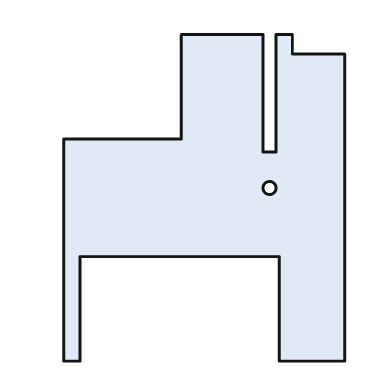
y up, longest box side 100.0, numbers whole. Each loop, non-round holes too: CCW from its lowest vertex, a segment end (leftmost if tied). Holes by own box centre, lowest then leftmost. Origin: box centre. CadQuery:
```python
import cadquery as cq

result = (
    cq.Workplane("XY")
    .moveTo(-43.0, -50.0)
    .lineTo(-38.0, -50.0)
    .lineTo(-38.0, -18.0)
    .lineTo(23.0, -18.0)
    .lineTo(23.0, -50.0)
    .lineTo(43.0, -50.0)
    .lineTo(43.0, 44.0)
    .lineTo(27.0, 44.0)
    .lineTo(27.0, 50.0)
    .lineTo(22.0, 50.0)
    .lineTo(22.0, 14.0)
    .lineTo(18.0, 14.0)
    .lineTo(18.0, 50.0)
    .lineTo(-7.0, 50.0)
    .lineTo(-7.0, 18.0)
    .lineTo(-43.0, 18.0)
    .close()
    .moveTo(20.0, 3.0)
    .circle(2.0)
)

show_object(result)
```